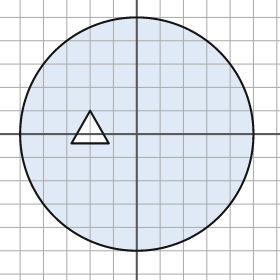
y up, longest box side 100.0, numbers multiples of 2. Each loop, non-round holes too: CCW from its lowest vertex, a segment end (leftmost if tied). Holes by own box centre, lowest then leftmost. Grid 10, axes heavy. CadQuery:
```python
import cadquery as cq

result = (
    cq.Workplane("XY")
    .moveTo(0.0, 0.0)
    .circle(50.0)
    .moveTo(-28.0, -4.0)
    .lineTo(-12.0, -4.0)
    .lineTo(-20.0, 10.0)
    .close()
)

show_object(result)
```